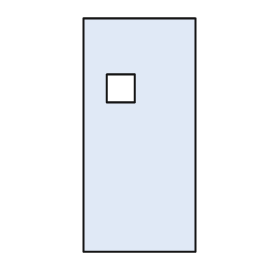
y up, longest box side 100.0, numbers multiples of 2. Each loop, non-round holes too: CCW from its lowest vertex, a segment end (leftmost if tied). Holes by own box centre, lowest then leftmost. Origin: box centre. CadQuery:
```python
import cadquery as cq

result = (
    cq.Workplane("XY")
    .moveTo(-24.0, -50.0)
    .lineTo(24.0, -50.0)
    .lineTo(24.0, 50.0)
    .lineTo(-24.0, 50.0)
    .close()
    .moveTo(-14.0, 14.0)
    .lineTo(-2.0, 14.0)
    .lineTo(-2.0, 26.0)
    .lineTo(-14.0, 26.0)
    .close()
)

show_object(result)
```